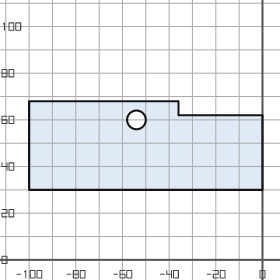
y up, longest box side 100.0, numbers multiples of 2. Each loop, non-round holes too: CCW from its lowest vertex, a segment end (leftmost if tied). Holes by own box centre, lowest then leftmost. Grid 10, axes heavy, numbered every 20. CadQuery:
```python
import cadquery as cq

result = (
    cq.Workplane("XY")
    .moveTo(-100.0, 30.0)
    .lineTo(0.0, 30.0)
    .lineTo(0.0, 62.0)
    .lineTo(-36.0, 62.0)
    .lineTo(-36.0, 68.0)
    .lineTo(-100.0, 68.0)
    .close()
    .moveTo(-54.0, 60.0)
    .circle(4.0)
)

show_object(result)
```